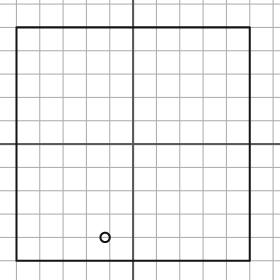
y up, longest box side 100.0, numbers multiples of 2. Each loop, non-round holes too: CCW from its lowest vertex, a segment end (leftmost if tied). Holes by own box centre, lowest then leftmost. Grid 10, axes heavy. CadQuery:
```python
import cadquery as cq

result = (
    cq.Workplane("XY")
    .moveTo(-50.0, -50.0)
    .lineTo(50.0, -50.0)
    .lineTo(50.0, 50.0)
    .lineTo(-50.0, 50.0)
    .close()
    .moveTo(-12.0, -40.0)
    .circle(2.0)
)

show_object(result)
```